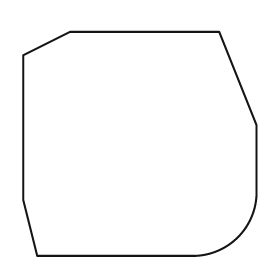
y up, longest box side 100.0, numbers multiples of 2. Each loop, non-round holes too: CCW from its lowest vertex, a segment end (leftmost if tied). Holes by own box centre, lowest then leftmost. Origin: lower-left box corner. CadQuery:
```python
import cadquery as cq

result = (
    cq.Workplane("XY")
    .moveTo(6.0, 0.0)
    .lineTo(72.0, 0.0)
    .threePointArc((92.0, 8.0), (100.0, 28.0))
    .lineTo(100.0, 56.0)
    .lineTo(84.0, 96.0)
    .lineTo(20.0, 96.0)
    .lineTo(0.0, 86.0)
    .lineTo(0.0, 24.0)
    .close()
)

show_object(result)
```